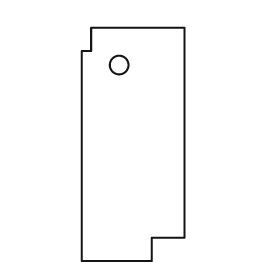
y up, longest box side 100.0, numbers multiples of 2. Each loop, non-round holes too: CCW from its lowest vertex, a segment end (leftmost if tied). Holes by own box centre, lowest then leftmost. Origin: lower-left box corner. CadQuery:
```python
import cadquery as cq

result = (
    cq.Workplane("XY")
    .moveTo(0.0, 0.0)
    .lineTo(30.0, 0.0)
    .lineTo(30.0, 10.0)
    .lineTo(44.0, 10.0)
    .lineTo(44.0, 100.0)
    .lineTo(4.0, 100.0)
    .lineTo(4.0, 90.0)
    .lineTo(0.0, 90.0)
    .close()
    .moveTo(16.0, 84.0)
    .circle(4.0)
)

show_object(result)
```